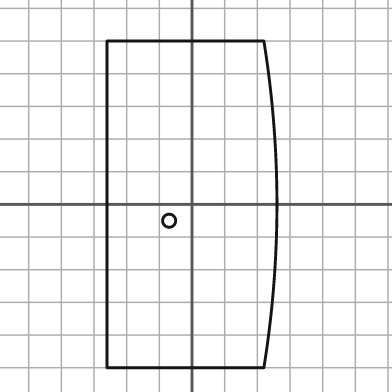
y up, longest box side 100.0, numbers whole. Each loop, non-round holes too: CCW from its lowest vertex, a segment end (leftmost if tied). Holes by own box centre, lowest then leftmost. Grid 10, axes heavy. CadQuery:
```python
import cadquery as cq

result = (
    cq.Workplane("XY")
    .moveTo(-26.0, -50.0)
    .lineTo(22.0, -50.0)
    .threePointArc((26.0, 0.0), (22.0, 50.0))
    .lineTo(-26.0, 50.0)
    .close()
    .moveTo(-7.0, -5.0)
    .circle(2.0)
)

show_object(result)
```